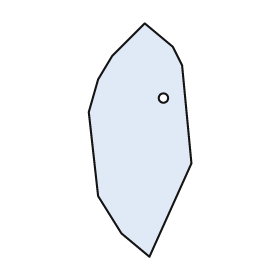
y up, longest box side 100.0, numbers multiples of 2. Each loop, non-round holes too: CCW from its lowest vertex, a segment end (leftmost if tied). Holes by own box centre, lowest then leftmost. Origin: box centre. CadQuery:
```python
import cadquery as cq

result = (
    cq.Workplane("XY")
    .moveTo(4.0, -50.0)
    .lineTo(22.0, -10.0)
    .lineTo(18.0, 32.0)
    .lineTo(14.0, 40.0)
    .lineTo(2.0, 50.0)
    .lineTo(-12.0, 36.0)
    .lineTo(-18.0, 26.0)
    .lineTo(-22.0, 12.0)
    .lineTo(-18.0, -24.0)
    .lineTo(-8.0, -40.0)
    .close()
    .moveTo(10.0, 18.0)
    .circle(2.0)
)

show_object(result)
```